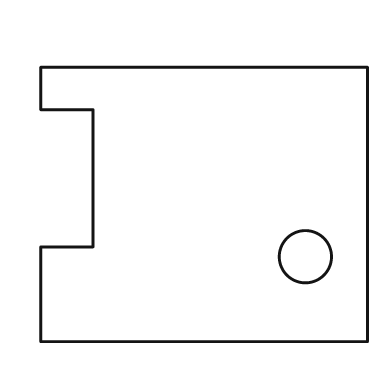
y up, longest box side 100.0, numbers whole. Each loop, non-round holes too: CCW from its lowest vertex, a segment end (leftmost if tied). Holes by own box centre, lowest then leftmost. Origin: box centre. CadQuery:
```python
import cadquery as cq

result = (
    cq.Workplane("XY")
    .moveTo(-50.0, -42.0)
    .lineTo(50.0, -42.0)
    .lineTo(50.0, 42.0)
    .lineTo(-50.0, 42.0)
    .lineTo(-50.0, 29.0)
    .lineTo(-34.0, 29.0)
    .lineTo(-34.0, -13.0)
    .lineTo(-50.0, -13.0)
    .close()
    .moveTo(31.0, -16.0)
    .circle(8.0)
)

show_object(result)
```